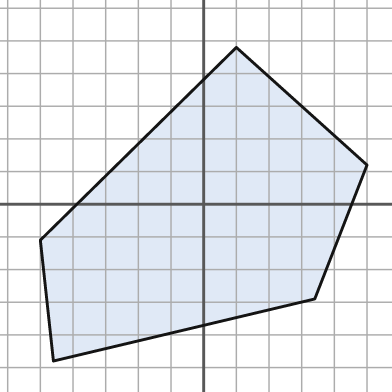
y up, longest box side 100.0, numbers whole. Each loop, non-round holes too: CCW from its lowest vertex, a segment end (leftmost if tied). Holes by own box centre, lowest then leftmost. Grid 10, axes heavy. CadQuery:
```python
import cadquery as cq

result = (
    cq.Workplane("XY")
    .moveTo(-46.0, -48.0)
    .lineTo(34.0, -29.0)
    .lineTo(50.0, 12.0)
    .lineTo(10.0, 48.0)
    .lineTo(-50.0, -11.0)
    .close()
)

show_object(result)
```